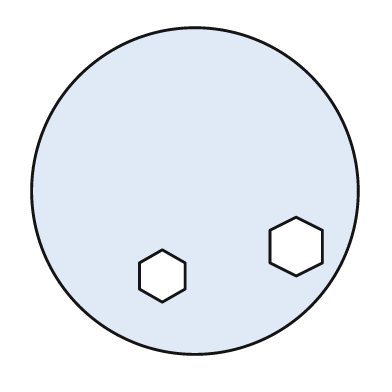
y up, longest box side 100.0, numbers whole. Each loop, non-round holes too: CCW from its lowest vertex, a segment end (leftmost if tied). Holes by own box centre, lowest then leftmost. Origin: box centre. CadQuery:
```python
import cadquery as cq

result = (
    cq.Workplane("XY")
    .moveTo(0.0, 0.0)
    .circle(50.0)
    .moveTo(-10.0, -34.0)
    .lineTo(-3.0, -30.0)
    .lineTo(-3.0, -22.0)
    .lineTo(-10.0, -18.0)
    .lineTo(-17.0, -22.0)
    .lineTo(-17.0, -30.0)
    .close()
    .moveTo(31.0, -26.0)
    .lineTo(39.0, -22.0)
    .lineTo(39.0, -12.0)
    .lineTo(31.0, -8.0)
    .lineTo(23.0, -12.0)
    .lineTo(23.0, -22.0)
    .close()
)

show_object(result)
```